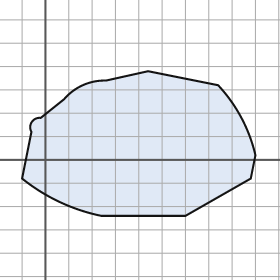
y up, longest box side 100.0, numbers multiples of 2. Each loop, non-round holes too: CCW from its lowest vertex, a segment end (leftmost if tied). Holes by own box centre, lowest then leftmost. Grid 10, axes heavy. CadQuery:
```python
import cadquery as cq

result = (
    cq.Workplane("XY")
    .moveTo(24.0, -24.0)
    .lineTo(60.0, -24.0)
    .lineTo(88.0, -8.0)
    .lineTo(90.0, 2.0)
    .threePointArc((84.0, 18.0), (74.0, 32.0))
    .lineTo(44.0, 38.0)
    .lineTo(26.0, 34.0)
    .threePointArc((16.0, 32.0), (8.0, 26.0))
    .lineTo(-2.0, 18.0)
    .threePointArc((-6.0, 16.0), (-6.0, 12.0))
    .lineTo(-10.0, -8.0)
    .threePointArc((6.0, -18.0), (24.0, -24.0))
    .close()
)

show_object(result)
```